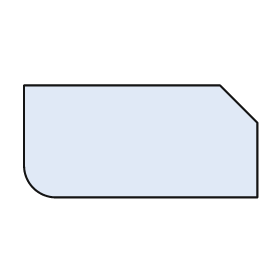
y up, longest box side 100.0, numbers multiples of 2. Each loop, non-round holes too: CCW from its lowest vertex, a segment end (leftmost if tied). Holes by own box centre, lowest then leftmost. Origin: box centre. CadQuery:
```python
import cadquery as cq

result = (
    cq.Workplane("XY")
    .moveTo(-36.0, -24.0)
    .lineTo(50.0, -24.0)
    .lineTo(50.0, 8.0)
    .lineTo(34.0, 24.0)
    .lineTo(-50.0, 24.0)
    .lineTo(-50.0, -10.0)
    .threePointArc((-46.0, -20.0), (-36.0, -24.0))
    .close()
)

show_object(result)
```